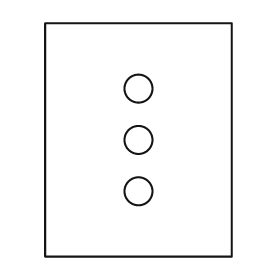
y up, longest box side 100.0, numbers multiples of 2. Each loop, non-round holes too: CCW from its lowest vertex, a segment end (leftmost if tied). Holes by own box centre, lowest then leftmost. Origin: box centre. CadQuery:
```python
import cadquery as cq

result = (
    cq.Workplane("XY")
    .moveTo(-40.0, -50.0)
    .lineTo(40.0, -50.0)
    .lineTo(40.0, 50.0)
    .lineTo(-40.0, 50.0)
    .close()
    .moveTo(0.0, -22.0)
    .circle(6.0)
    .moveTo(0.0, 0.0)
    .circle(6.0)
    .moveTo(0.0, 22.0)
    .circle(6.0)
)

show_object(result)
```